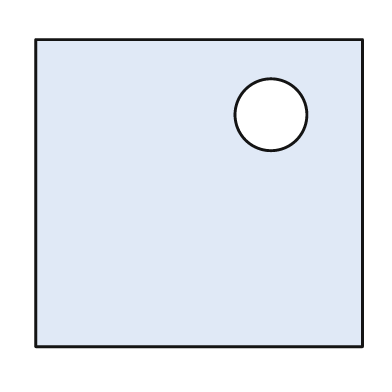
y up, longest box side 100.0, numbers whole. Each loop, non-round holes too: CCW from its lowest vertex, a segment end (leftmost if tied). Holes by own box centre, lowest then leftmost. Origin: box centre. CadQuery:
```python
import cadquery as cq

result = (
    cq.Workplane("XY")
    .moveTo(-50.0, -47.0)
    .lineTo(50.0, -47.0)
    .lineTo(50.0, 47.0)
    .lineTo(-50.0, 47.0)
    .close()
    .moveTo(22.0, 24.0)
    .circle(11.0)
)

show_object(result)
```